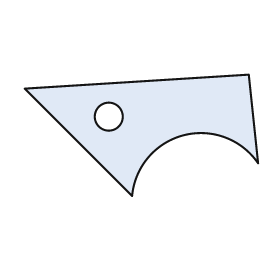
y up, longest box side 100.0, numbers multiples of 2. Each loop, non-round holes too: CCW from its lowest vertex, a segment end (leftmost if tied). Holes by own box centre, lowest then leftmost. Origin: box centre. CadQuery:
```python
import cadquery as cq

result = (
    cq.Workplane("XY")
    .moveTo(-4.0, -26.0)
    .threePointArc((18.0, 0.0), (50.0, -12.0))
    .lineTo(46.0, 26.0)
    .lineTo(-50.0, 20.0)
    .close()
    .moveTo(-14.0, 8.0)
    .circle(6.0)
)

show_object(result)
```